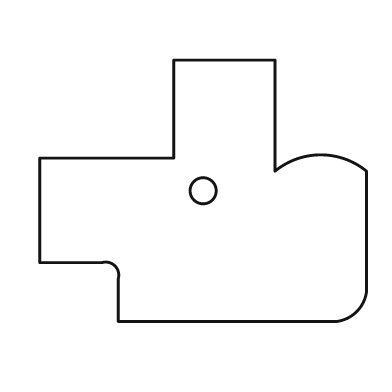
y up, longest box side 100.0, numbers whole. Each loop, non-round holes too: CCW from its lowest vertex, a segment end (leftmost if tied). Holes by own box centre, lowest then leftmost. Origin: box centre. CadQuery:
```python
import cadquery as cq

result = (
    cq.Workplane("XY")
    .moveTo(-26.0, -40.0)
    .lineTo(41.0, -40.0)
    .threePointArc((47.0, -37.0), (50.0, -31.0))
    .lineTo(50.0, 6.0)
    .threePointArc((36.0, 11.0), (22.0, 6.0))
    .lineTo(22.0, 40.0)
    .lineTo(-9.0, 40.0)
    .lineTo(-9.0, 10.0)
    .lineTo(-50.0, 10.0)
    .lineTo(-50.0, -22.0)
    .lineTo(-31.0, -22.0)
    .threePointArc((-27.0, -23.0), (-26.0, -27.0))
    .close()
    .moveTo(0.0, 0.0)
    .circle(4.0)
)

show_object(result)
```